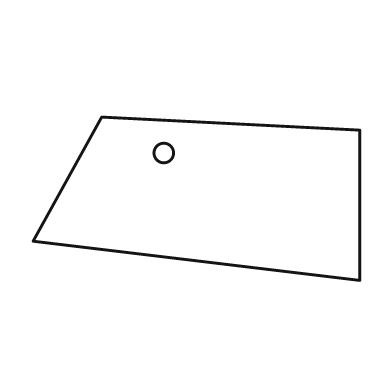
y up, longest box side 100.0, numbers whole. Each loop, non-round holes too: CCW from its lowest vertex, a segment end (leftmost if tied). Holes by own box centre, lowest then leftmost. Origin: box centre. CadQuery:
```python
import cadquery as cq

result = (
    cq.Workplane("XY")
    .moveTo(50.0, -25.0)
    .lineTo(50.0, 21.0)
    .lineTo(-29.0, 25.0)
    .lineTo(-50.0, -13.0)
    .close()
    .moveTo(-10.0, 14.0)
    .circle(3.0)
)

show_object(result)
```